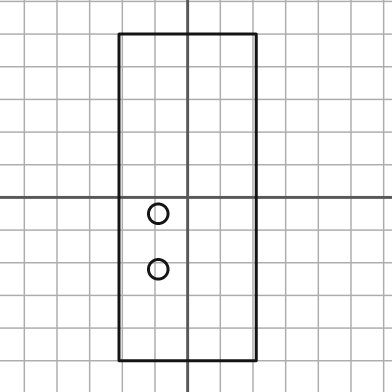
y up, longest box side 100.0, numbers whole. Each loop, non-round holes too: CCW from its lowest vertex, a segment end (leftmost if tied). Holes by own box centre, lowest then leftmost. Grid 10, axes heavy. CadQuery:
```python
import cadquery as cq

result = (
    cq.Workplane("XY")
    .moveTo(-21.0, -50.0)
    .lineTo(21.0, -50.0)
    .lineTo(21.0, 50.0)
    .lineTo(-21.0, 50.0)
    .close()
    .moveTo(-9.0, -22.0)
    .circle(3.0)
    .moveTo(-9.0, -5.0)
    .circle(3.0)
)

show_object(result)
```